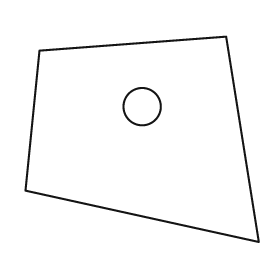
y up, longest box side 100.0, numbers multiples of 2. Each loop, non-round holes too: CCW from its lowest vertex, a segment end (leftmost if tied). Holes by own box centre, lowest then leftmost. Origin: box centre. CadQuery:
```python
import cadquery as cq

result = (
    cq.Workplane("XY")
    .moveTo(50.0, -44.0)
    .lineTo(36.0, 44.0)
    .lineTo(-44.0, 38.0)
    .lineTo(-50.0, -22.0)
    .close()
    .moveTo(0.0, 14.0)
    .circle(8.0)
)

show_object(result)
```